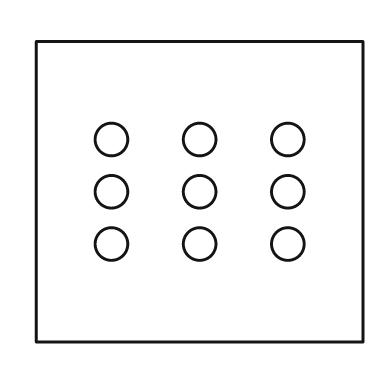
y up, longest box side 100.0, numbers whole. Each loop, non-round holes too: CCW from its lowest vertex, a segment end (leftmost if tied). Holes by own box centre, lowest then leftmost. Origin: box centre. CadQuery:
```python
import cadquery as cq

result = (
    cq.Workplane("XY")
    .moveTo(-50.0, -46.0)
    .lineTo(50.0, -46.0)
    .lineTo(50.0, 46.0)
    .lineTo(-50.0, 46.0)
    .close()
    .moveTo(-27.0, -16.0)
    .circle(5.0)
    .moveTo(0.0, -16.0)
    .circle(5.0)
    .moveTo(27.0, -16.0)
    .circle(5.0)
    .moveTo(-27.0, 0.0)
    .circle(5.0)
    .moveTo(0.0, 0.0)
    .circle(5.0)
    .moveTo(27.0, 0.0)
    .circle(5.0)
    .moveTo(-27.0, 16.0)
    .circle(5.0)
    .moveTo(0.0, 16.0)
    .circle(5.0)
    .moveTo(27.0, 16.0)
    .circle(5.0)
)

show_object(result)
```